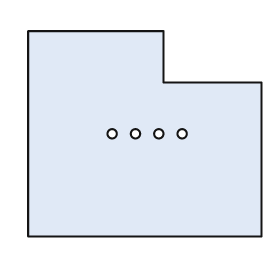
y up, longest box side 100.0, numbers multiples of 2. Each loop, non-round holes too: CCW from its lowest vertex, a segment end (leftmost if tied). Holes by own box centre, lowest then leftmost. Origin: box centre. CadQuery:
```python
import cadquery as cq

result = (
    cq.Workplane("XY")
    .moveTo(-50.0, -44.0)
    .lineTo(50.0, -44.0)
    .lineTo(50.0, 22.0)
    .lineTo(8.0, 22.0)
    .lineTo(8.0, 44.0)
    .lineTo(-50.0, 44.0)
    .close()
    .moveTo(-14.0, 0.0)
    .circle(2.0)
    .moveTo(-4.0, 0.0)
    .circle(2.0)
    .moveTo(6.0, 0.0)
    .circle(2.0)
    .moveTo(16.0, 0.0)
    .circle(2.0)
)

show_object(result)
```